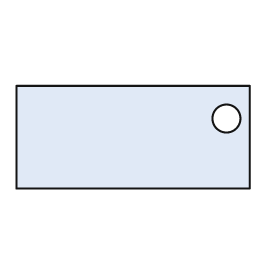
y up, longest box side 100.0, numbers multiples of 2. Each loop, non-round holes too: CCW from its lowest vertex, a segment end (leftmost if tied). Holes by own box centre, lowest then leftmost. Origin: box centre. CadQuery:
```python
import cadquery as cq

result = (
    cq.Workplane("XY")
    .moveTo(-50.0, -22.0)
    .lineTo(50.0, -22.0)
    .lineTo(50.0, 22.0)
    .lineTo(-50.0, 22.0)
    .close()
    .moveTo(40.0, 8.0)
    .circle(6.0)
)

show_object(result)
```